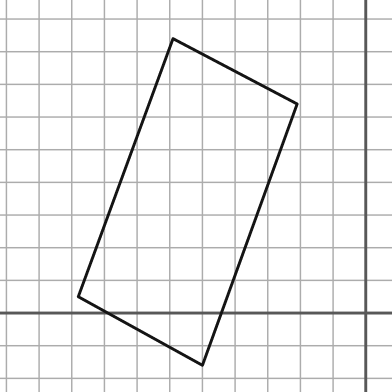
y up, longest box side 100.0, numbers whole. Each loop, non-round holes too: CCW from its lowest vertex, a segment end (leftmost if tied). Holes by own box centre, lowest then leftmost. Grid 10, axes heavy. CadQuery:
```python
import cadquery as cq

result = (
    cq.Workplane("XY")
    .moveTo(-50.0, -16.0)
    .lineTo(-21.0, 64.0)
    .lineTo(-59.0, 84.0)
    .lineTo(-88.0, 5.0)
    .close()
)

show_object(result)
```